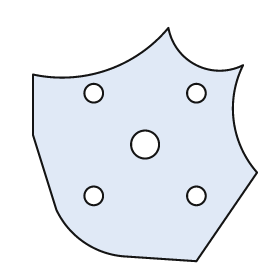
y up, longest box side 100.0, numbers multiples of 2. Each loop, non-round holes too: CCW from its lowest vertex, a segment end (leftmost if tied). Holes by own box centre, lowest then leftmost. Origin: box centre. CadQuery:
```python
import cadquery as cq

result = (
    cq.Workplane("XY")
    .moveTo(22.0, -50.0)
    .lineTo(48.0, -12.0)
    .threePointArc((38.0, 10.0), (42.0, 34.0))
    .threePointArc((22.0, 34.0), (10.0, 50.0))
    .threePointArc((-16.0, 32.0), (-48.0, 30.0))
    .lineTo(-48.0, 4.0)
    .lineTo(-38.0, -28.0)
    .threePointArc((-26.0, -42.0), (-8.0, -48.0))
    .close()
    .moveTo(-22.0, -22.0)
    .circle(4.0)
    .moveTo(22.0, -22.0)
    .circle(4.0)
    .moveTo(0.0, 0.0)
    .circle(6.0)
    .moveTo(-22.0, 22.0)
    .circle(4.0)
    .moveTo(22.0, 22.0)
    .circle(4.0)
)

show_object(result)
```